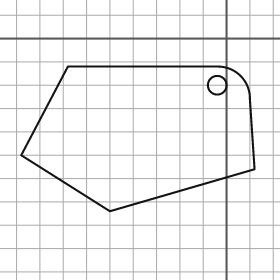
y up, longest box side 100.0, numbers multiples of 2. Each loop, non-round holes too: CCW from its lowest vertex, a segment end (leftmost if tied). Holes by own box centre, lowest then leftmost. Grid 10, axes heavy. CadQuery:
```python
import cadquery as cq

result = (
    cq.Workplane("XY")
    .moveTo(-50.0, -74.0)
    .lineTo(12.0, -56.0)
    .lineTo(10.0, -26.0)
    .threePointArc((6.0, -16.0), (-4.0, -12.0))
    .lineTo(-68.0, -12.0)
    .lineTo(-88.0, -50.0)
    .close()
    .moveTo(-4.0, -20.0)
    .circle(4.0)
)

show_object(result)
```